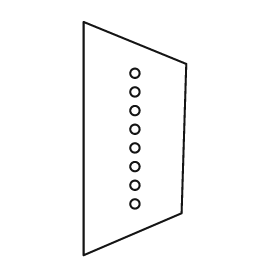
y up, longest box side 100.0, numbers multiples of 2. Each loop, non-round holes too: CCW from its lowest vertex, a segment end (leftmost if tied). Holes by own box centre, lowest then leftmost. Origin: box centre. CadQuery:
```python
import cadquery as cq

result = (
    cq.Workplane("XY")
    .moveTo(-22.0, -50.0)
    .lineTo(20.0, -32.0)
    .lineTo(22.0, 32.0)
    .lineTo(-22.0, 50.0)
    .close()
    .moveTo(0.0, -28.0)
    .circle(2.0)
    .moveTo(0.0, -20.0)
    .circle(2.0)
    .moveTo(0.0, -12.0)
    .circle(2.0)
    .moveTo(0.0, -4.0)
    .circle(2.0)
    .moveTo(0.0, 4.0)
    .circle(2.0)
    .moveTo(0.0, 12.0)
    .circle(2.0)
    .moveTo(0.0, 20.0)
    .circle(2.0)
    .moveTo(0.0, 28.0)
    .circle(2.0)
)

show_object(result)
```